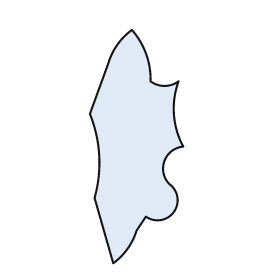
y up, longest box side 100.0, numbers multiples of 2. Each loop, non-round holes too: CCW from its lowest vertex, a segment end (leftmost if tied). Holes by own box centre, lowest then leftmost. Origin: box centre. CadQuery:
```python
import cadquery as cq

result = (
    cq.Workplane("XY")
    .moveTo(-10.0, -50.0)
    .threePointArc((-4.0, -44.0), (0.0, -36.0))
    .lineTo(4.0, -30.0)
    .threePointArc((16.0, -28.0), (14.0, -16.0))
    .threePointArc((12.0, -6.0), (20.0, 0.0))
    .threePointArc((16.0, 14.0), (18.0, 28.0))
    .threePointArc((12.0, 26.0), (6.0, 28.0))
    .threePointArc((4.0, 40.0), (-2.0, 50.0))
    .threePointArc((-8.0, 44.0), (-12.0, 36.0))
    .lineTo(-20.0, 14.0)
    .threePointArc((-16.0, -4.0), (-18.0, -22.0))
    .close()
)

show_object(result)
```